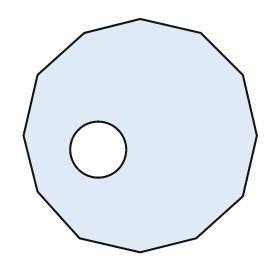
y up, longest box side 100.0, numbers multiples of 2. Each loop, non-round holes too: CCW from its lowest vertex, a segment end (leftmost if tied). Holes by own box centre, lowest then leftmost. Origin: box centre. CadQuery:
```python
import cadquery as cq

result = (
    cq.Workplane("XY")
    .moveTo(0.0, -50.0)
    .lineTo(24.0, -44.0)
    .lineTo(44.0, -26.0)
    .lineTo(50.0, 0.0)
    .lineTo(44.0, 26.0)
    .lineTo(26.0, 44.0)
    .lineTo(0.0, 50.0)
    .lineTo(-24.0, 44.0)
    .lineTo(-44.0, 26.0)
    .lineTo(-50.0, 0.0)
    .lineTo(-44.0, -24.0)
    .lineTo(-26.0, -44.0)
    .close()
    .moveTo(-18.0, -6.0)
    .circle(12.0)
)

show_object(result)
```